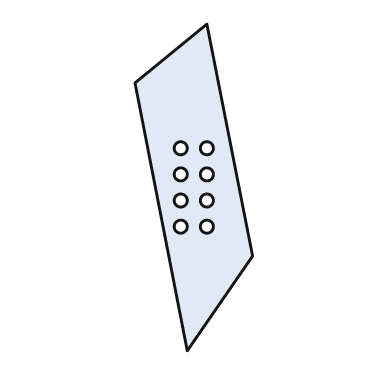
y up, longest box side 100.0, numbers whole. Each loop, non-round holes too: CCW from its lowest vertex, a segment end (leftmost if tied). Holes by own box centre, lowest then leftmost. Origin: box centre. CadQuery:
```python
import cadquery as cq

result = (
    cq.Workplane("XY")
    .moveTo(-2.0, -50.0)
    .lineTo(18.0, -21.0)
    .lineTo(4.0, 50.0)
    .lineTo(-18.0, 32.0)
    .close()
    .moveTo(-4.0, -12.0)
    .circle(2.0)
    .moveTo(4.0, -12.0)
    .circle(2.0)
    .moveTo(-4.0, -4.0)
    .circle(2.0)
    .moveTo(4.0, -4.0)
    .circle(2.0)
    .moveTo(-4.0, 4.0)
    .circle(2.0)
    .moveTo(4.0, 4.0)
    .circle(2.0)
    .moveTo(-4.0, 12.0)
    .circle(2.0)
    .moveTo(4.0, 12.0)
    .circle(2.0)
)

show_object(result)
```